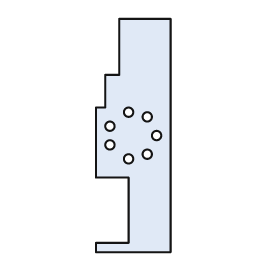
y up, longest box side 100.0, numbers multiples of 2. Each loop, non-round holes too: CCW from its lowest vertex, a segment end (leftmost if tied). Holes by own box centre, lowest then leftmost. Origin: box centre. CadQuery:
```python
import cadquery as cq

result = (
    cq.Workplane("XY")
    .moveTo(-16.0, -50.0)
    .lineTo(16.0, -50.0)
    .lineTo(16.0, 50.0)
    .lineTo(-6.0, 50.0)
    .lineTo(-6.0, 26.0)
    .lineTo(-12.0, 26.0)
    .lineTo(-12.0, 12.0)
    .lineTo(-16.0, 12.0)
    .lineTo(-16.0, -18.0)
    .lineTo(-2.0, -18.0)
    .lineTo(-2.0, -46.0)
    .lineTo(-16.0, -46.0)
    .close()
    .moveTo(-2.0, -10.0)
    .circle(2.0)
    .moveTo(6.0, -8.0)
    .circle(2.0)
    .moveTo(-10.0, -4.0)
    .circle(2.0)
    .moveTo(10.0, 0.0)
    .circle(2.0)
    .moveTo(-10.0, 4.0)
    .circle(2.0)
    .moveTo(6.0, 8.0)
    .circle(2.0)
    .moveTo(-2.0, 10.0)
    .circle(2.0)
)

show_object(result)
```